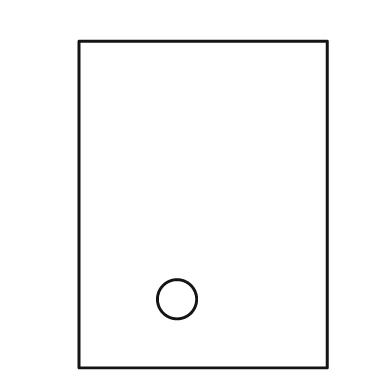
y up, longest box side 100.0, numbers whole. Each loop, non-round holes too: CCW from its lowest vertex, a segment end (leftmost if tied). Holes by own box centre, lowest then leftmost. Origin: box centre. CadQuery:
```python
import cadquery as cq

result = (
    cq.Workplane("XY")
    .moveTo(-38.0, -50.0)
    .lineTo(38.0, -50.0)
    .lineTo(38.0, 50.0)
    .lineTo(-38.0, 50.0)
    .close()
    .moveTo(-8.0, -29.0)
    .circle(6.0)
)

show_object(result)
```